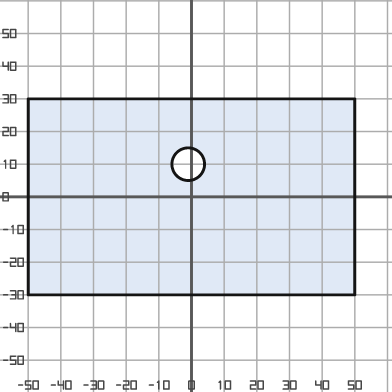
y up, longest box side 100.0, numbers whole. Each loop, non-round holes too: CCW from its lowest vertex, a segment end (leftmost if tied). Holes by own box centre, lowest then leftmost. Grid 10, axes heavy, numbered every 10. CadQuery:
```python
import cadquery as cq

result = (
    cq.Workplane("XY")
    .moveTo(-50.0, -30.0)
    .lineTo(50.0, -30.0)
    .lineTo(50.0, 30.0)
    .lineTo(-50.0, 30.0)
    .close()
    .moveTo(-1.0, 10.0)
    .circle(5.0)
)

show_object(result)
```